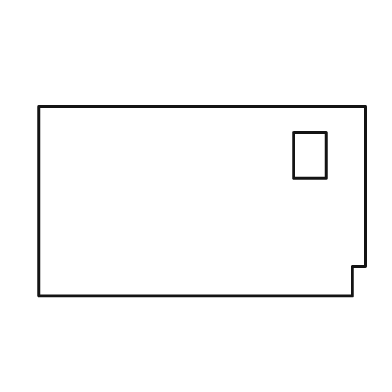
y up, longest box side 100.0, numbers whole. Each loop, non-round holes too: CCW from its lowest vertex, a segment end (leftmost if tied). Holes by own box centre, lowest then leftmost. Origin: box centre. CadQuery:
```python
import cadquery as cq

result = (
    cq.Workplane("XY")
    .moveTo(-50.0, -29.0)
    .lineTo(46.0, -29.0)
    .lineTo(46.0, -20.0)
    .lineTo(50.0, -20.0)
    .lineTo(50.0, 29.0)
    .lineTo(-50.0, 29.0)
    .close()
    .moveTo(28.0, 7.0)
    .lineTo(38.0, 7.0)
    .lineTo(38.0, 21.0)
    .lineTo(28.0, 21.0)
    .close()
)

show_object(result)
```